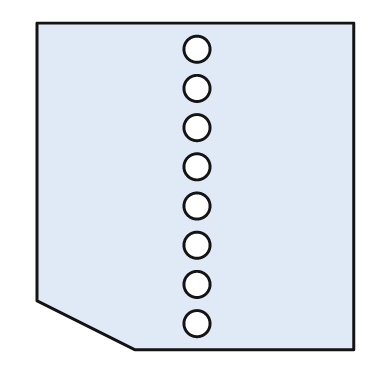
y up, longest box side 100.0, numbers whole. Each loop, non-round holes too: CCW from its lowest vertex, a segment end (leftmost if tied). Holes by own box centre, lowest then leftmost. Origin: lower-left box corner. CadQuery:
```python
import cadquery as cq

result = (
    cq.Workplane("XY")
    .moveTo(30.0, 0.0)
    .lineTo(97.0, 0.0)
    .lineTo(97.0, 100.0)
    .lineTo(0.0, 100.0)
    .lineTo(0.0, 15.0)
    .close()
    .moveTo(49.0, 8.0)
    .circle(4.0)
    .moveTo(49.0, 20.0)
    .circle(4.0)
    .moveTo(49.0, 32.0)
    .circle(4.0)
    .moveTo(49.0, 44.0)
    .circle(4.0)
    .moveTo(49.0, 56.0)
    .circle(4.0)
    .moveTo(49.0, 68.0)
    .circle(4.0)
    .moveTo(49.0, 80.0)
    .circle(4.0)
    .moveTo(49.0, 92.0)
    .circle(4.0)
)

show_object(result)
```